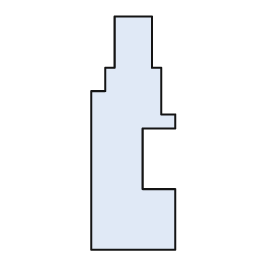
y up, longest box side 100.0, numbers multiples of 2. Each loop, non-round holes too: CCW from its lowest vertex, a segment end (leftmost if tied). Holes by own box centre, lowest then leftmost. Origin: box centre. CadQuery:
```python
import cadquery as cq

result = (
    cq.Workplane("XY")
    .moveTo(-18.0, -50.0)
    .lineTo(18.0, -50.0)
    .lineTo(18.0, -24.0)
    .lineTo(4.0, -24.0)
    .lineTo(4.0, 2.0)
    .lineTo(18.0, 2.0)
    .lineTo(18.0, 8.0)
    .lineTo(12.0, 8.0)
    .lineTo(12.0, 28.0)
    .lineTo(8.0, 28.0)
    .lineTo(8.0, 50.0)
    .lineTo(-8.0, 50.0)
    .lineTo(-8.0, 28.0)
    .lineTo(-12.0, 28.0)
    .lineTo(-12.0, 18.0)
    .lineTo(-18.0, 18.0)
    .close()
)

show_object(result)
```